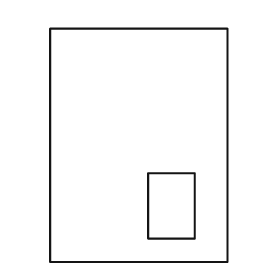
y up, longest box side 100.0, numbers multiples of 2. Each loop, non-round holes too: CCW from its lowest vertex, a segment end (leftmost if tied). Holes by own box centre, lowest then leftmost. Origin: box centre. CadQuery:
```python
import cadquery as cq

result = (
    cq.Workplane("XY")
    .moveTo(-38.0, -50.0)
    .lineTo(38.0, -50.0)
    .lineTo(38.0, 50.0)
    .lineTo(-38.0, 50.0)
    .close()
    .moveTo(4.0, -40.0)
    .lineTo(24.0, -40.0)
    .lineTo(24.0, -12.0)
    .lineTo(4.0, -12.0)
    .close()
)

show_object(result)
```